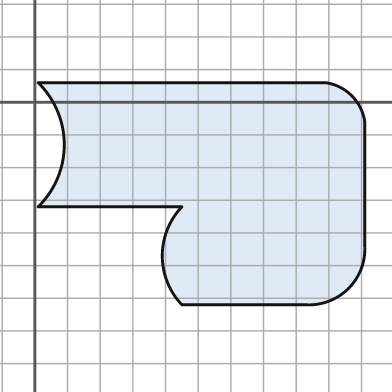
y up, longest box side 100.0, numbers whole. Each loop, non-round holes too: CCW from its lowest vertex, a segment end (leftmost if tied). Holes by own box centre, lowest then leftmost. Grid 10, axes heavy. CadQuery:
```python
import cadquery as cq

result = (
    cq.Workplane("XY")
    .moveTo(45.0, -62.0)
    .lineTo(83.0, -62.0)
    .threePointArc((96.0, -57.0), (101.0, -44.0))
    .lineTo(101.0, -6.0)
    .threePointArc((97.0, 2.0), (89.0, 6.0))
    .lineTo(1.0, 6.0)
    .threePointArc((9.0, -13.0), (1.0, -32.0))
    .lineTo(45.0, -32.0)
    .threePointArc((39.0, -47.0), (45.0, -62.0))
    .close()
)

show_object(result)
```